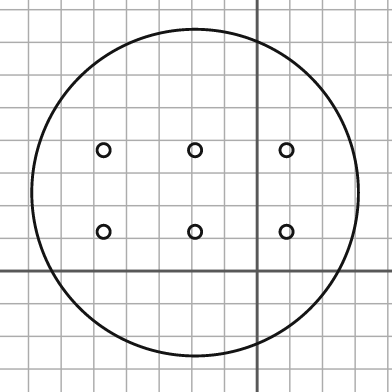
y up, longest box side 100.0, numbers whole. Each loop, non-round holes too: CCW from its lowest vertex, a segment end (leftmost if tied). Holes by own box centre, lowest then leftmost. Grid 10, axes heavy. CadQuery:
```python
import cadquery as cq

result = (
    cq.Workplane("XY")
    .moveTo(-19.0, 24.0)
    .circle(50.0)
    .moveTo(-47.0, 12.0)
    .circle(2.0)
    .moveTo(-19.0, 12.0)
    .circle(2.0)
    .moveTo(9.0, 12.0)
    .circle(2.0)
    .moveTo(-47.0, 37.0)
    .circle(2.0)
    .moveTo(-19.0, 37.0)
    .circle(2.0)
    .moveTo(9.0, 37.0)
    .circle(2.0)
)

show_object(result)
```